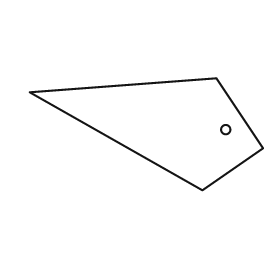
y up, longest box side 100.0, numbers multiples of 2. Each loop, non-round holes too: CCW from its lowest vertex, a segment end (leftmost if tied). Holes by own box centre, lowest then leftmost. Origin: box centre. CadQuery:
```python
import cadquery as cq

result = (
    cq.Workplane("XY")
    .moveTo(24.0, -24.0)
    .lineTo(50.0, -6.0)
    .lineTo(30.0, 24.0)
    .lineTo(-50.0, 18.0)
    .close()
    .moveTo(34.0, 2.0)
    .circle(2.0)
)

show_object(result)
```